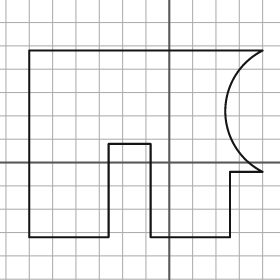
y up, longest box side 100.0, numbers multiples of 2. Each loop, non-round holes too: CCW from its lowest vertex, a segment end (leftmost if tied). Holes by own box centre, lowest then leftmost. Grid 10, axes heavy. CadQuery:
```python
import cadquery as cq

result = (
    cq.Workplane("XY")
    .moveTo(-60.0, -32.0)
    .lineTo(-26.0, -32.0)
    .lineTo(-26.0, 8.0)
    .lineTo(-8.0, 8.0)
    .lineTo(-8.0, -32.0)
    .lineTo(26.0, -32.0)
    .lineTo(26.0, -4.0)
    .lineTo(40.0, -4.0)
    .threePointArc((24.0, 22.0), (40.0, 48.0))
    .lineTo(-60.0, 48.0)
    .close()
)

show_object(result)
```